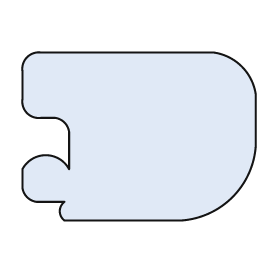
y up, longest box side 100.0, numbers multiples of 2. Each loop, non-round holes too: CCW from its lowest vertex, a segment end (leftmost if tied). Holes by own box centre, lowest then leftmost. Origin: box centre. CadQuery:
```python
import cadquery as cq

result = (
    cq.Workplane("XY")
    .moveTo(-32.0, -36.0)
    .lineTo(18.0, -36.0)
    .threePointArc((40.0, -26.0), (50.0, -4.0))
    .lineTo(50.0, 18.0)
    .threePointArc((44.0, 30.0), (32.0, 36.0))
    .lineTo(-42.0, 36.0)
    .threePointArc((-48.0, 34.0), (-50.0, 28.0))
    .lineTo(-50.0, 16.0)
    .threePointArc((-48.0, 10.0), (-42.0, 8.0))
    .lineTo(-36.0, 8.0)
    .threePointArc((-32.0, 6.0), (-30.0, 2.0))
    .lineTo(-30.0, -14.0)
    .threePointArc((-40.0, -8.0), (-50.0, -14.0))
    .lineTo(-50.0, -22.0)
    .threePointArc((-48.0, -26.0), (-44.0, -28.0))
    .lineTo(-32.0, -28.0)
    .threePointArc((-34.0, -32.0), (-32.0, -36.0))
    .close()
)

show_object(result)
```